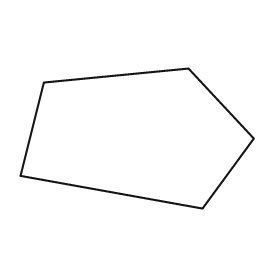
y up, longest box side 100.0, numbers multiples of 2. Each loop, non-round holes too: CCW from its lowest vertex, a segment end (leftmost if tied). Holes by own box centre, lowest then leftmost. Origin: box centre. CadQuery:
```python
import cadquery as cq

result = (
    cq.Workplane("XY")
    .moveTo(28.0, -30.0)
    .lineTo(50.0, 0.0)
    .lineTo(22.0, 30.0)
    .lineTo(-40.0, 24.0)
    .lineTo(-50.0, -16.0)
    .close()
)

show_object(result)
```